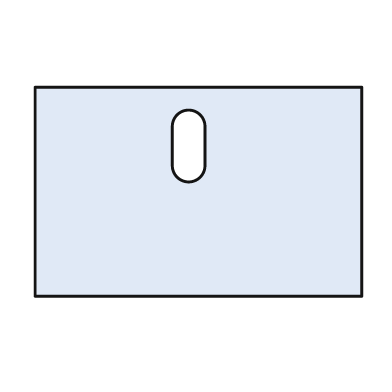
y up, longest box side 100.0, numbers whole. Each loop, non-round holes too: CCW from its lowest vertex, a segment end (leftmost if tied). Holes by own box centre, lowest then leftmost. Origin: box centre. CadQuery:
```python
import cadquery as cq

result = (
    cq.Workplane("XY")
    .moveTo(-50.0, -32.0)
    .lineTo(50.0, -32.0)
    .lineTo(50.0, 32.0)
    .lineTo(-50.0, 32.0)
    .close()
    .moveTo(-8.0, 8.0)
    .threePointArc((-3.0, 3.0), (2.0, 8.0))
    .lineTo(2.0, 20.0)
    .threePointArc((-3.0, 25.0), (-8.0, 20.0))
    .close()
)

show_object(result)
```